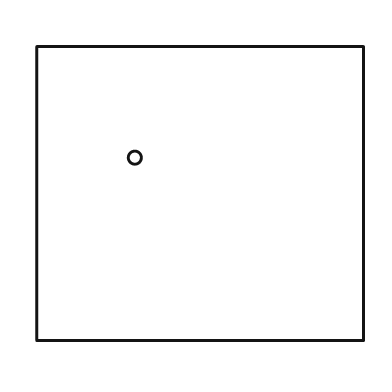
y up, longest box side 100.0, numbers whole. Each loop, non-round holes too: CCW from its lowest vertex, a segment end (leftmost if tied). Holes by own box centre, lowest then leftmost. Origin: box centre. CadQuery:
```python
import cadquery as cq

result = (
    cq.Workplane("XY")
    .moveTo(-50.0, -45.0)
    .lineTo(50.0, -45.0)
    .lineTo(50.0, 45.0)
    .lineTo(-50.0, 45.0)
    .close()
    .moveTo(-20.0, 11.0)
    .circle(2.0)
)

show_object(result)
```